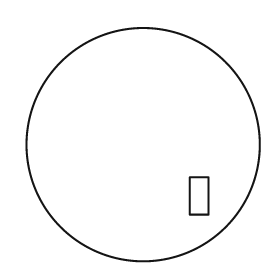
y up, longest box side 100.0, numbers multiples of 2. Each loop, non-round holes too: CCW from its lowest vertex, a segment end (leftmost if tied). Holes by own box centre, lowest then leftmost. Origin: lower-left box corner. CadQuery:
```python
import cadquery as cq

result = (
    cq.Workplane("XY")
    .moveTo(50.0, 50.0)
    .circle(50.0)
    .moveTo(70.0, 20.0)
    .lineTo(78.0, 20.0)
    .lineTo(78.0, 36.0)
    .lineTo(70.0, 36.0)
    .close()
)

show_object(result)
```